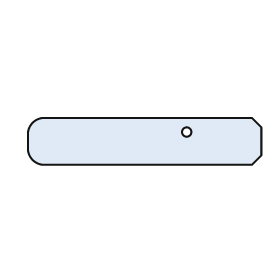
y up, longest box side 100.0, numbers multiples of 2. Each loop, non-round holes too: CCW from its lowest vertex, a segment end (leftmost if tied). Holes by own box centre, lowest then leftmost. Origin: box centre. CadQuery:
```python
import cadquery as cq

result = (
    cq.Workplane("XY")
    .moveTo(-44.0, -10.0)
    .lineTo(46.0, -10.0)
    .lineTo(50.0, -6.0)
    .lineTo(50.0, 6.0)
    .lineTo(46.0, 10.0)
    .lineTo(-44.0, 10.0)
    .threePointArc((-48.0, 8.0), (-50.0, 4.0))
    .lineTo(-50.0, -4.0)
    .threePointArc((-48.0, -8.0), (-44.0, -10.0))
    .close()
    .moveTo(18.0, 4.0)
    .circle(2.0)
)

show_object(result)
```